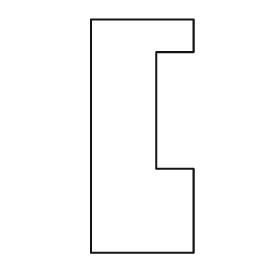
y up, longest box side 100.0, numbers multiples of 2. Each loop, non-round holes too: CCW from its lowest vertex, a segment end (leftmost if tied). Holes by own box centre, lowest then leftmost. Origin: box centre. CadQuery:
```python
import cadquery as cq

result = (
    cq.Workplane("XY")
    .moveTo(-22.0, -50.0)
    .lineTo(22.0, -50.0)
    .lineTo(22.0, -14.0)
    .lineTo(6.0, -14.0)
    .lineTo(6.0, 36.0)
    .lineTo(22.0, 36.0)
    .lineTo(22.0, 50.0)
    .lineTo(-22.0, 50.0)
    .close()
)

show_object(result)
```